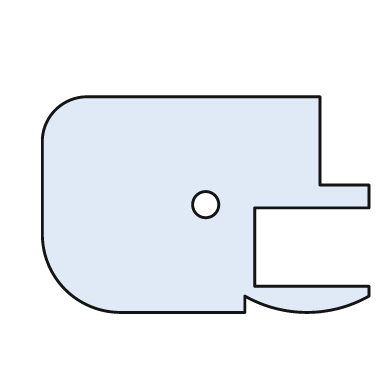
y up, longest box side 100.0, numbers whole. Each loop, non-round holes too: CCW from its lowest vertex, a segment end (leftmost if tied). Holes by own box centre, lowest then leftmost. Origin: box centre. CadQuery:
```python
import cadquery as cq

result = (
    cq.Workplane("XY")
    .moveTo(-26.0, -33.0)
    .lineTo(12.0, -33.0)
    .lineTo(12.0, -28.0)
    .threePointArc((31.0, -33.0), (50.0, -28.0))
    .lineTo(50.0, -25.0)
    .lineTo(15.0, -25.0)
    .lineTo(15.0, -1.0)
    .lineTo(50.0, -1.0)
    .lineTo(50.0, 6.0)
    .lineTo(35.0, 6.0)
    .lineTo(35.0, 33.0)
    .lineTo(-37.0, 33.0)
    .threePointArc((-46.0, 29.0), (-50.0, 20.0))
    .lineTo(-50.0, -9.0)
    .threePointArc((-43.0, -26.0), (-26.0, -33.0))
    .close()
    .moveTo(0.0, 0.0)
    .circle(4.0)
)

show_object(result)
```